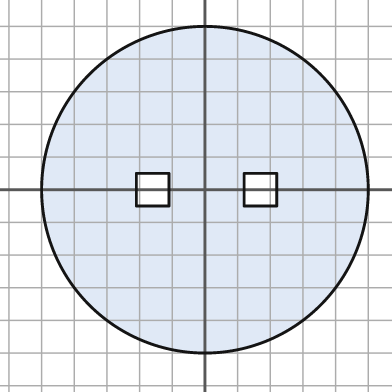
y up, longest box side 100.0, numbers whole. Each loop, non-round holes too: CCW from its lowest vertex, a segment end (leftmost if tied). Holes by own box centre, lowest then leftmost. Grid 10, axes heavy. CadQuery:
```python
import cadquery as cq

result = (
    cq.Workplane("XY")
    .moveTo(0.0, 0.0)
    .circle(50.0)
    .moveTo(-21.0, -5.0)
    .lineTo(-11.0, -5.0)
    .lineTo(-11.0, 5.0)
    .lineTo(-21.0, 5.0)
    .close()
    .moveTo(12.0, -5.0)
    .lineTo(22.0, -5.0)
    .lineTo(22.0, 5.0)
    .lineTo(12.0, 5.0)
    .close()
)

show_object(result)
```